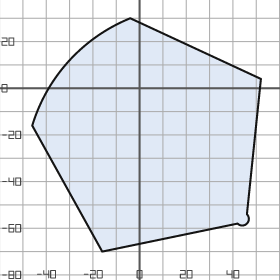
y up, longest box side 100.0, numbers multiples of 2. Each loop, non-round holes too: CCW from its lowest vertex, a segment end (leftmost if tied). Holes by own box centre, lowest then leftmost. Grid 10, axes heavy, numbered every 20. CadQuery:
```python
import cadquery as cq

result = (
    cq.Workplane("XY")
    .moveTo(-16.0, -70.0)
    .lineTo(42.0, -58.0)
    .threePointArc((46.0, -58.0), (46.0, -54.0))
    .lineTo(52.0, 4.0)
    .lineTo(-4.0, 30.0)
    .threePointArc((-30.0, 12.0), (-46.0, -16.0))
    .close()
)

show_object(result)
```